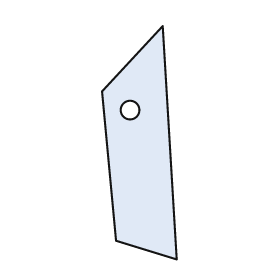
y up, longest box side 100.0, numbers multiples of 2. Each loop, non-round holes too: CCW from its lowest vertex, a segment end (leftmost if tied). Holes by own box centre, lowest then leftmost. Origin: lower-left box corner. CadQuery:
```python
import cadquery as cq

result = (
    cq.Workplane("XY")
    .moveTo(32.0, 0.0)
    .lineTo(26.0, 100.0)
    .lineTo(0.0, 72.0)
    .lineTo(6.0, 8.0)
    .close()
    .moveTo(12.0, 64.0)
    .circle(4.0)
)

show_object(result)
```